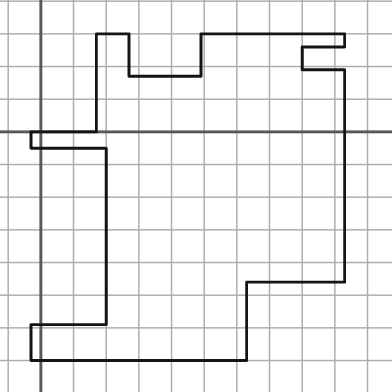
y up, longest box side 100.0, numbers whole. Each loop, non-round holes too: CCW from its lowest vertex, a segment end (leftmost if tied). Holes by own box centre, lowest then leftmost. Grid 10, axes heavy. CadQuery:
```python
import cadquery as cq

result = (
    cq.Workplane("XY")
    .moveTo(-3.0, -70.0)
    .lineTo(63.0, -70.0)
    .lineTo(63.0, -46.0)
    .lineTo(93.0, -46.0)
    .lineTo(93.0, 19.0)
    .lineTo(80.0, 19.0)
    .lineTo(80.0, 26.0)
    .lineTo(93.0, 26.0)
    .lineTo(93.0, 30.0)
    .lineTo(49.0, 30.0)
    .lineTo(49.0, 17.0)
    .lineTo(27.0, 17.0)
    .lineTo(27.0, 30.0)
    .lineTo(17.0, 30.0)
    .lineTo(17.0, 0.0)
    .lineTo(-3.0, 0.0)
    .lineTo(-3.0, -5.0)
    .lineTo(20.0, -5.0)
    .lineTo(20.0, -59.0)
    .lineTo(-3.0, -59.0)
    .close()
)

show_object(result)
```